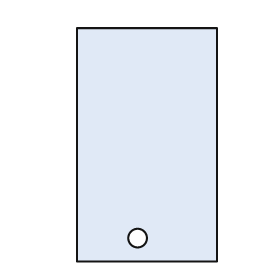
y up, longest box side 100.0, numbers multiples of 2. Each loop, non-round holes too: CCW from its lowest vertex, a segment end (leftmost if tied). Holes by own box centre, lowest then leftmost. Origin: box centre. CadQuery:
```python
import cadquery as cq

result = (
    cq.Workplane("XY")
    .moveTo(-30.0, -50.0)
    .lineTo(30.0, -50.0)
    .lineTo(30.0, 50.0)
    .lineTo(-30.0, 50.0)
    .close()
    .moveTo(-4.0, -40.0)
    .circle(4.0)
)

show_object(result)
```